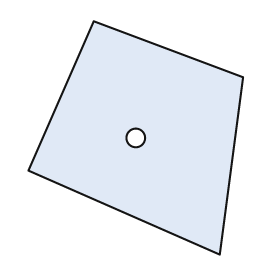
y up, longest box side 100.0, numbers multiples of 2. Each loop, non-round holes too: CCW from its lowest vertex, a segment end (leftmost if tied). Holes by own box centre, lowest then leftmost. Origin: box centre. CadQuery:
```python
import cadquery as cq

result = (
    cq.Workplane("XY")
    .moveTo(36.0, -50.0)
    .lineTo(46.0, 26.0)
    .lineTo(-18.0, 50.0)
    .lineTo(-46.0, -14.0)
    .close()
    .moveTo(0.0, 0.0)
    .circle(4.0)
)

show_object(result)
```